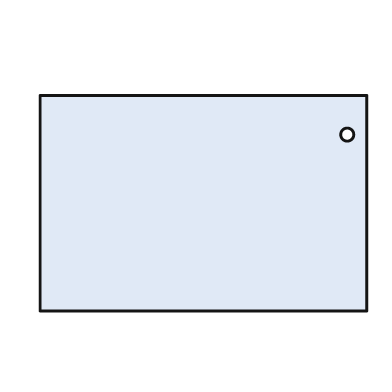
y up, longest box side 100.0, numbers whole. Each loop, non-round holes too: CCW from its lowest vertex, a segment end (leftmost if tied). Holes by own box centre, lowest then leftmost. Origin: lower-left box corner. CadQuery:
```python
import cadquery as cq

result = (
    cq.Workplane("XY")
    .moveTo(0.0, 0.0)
    .lineTo(100.0, 0.0)
    .lineTo(100.0, 66.0)
    .lineTo(0.0, 66.0)
    .close()
    .moveTo(94.0, 54.0)
    .circle(2.0)
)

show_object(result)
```